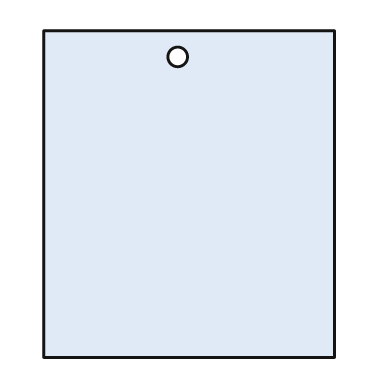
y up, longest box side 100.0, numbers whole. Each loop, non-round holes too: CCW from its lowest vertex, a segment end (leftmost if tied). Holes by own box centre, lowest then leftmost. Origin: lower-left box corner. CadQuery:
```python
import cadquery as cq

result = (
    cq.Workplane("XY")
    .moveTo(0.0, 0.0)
    .lineTo(89.0, 0.0)
    .lineTo(89.0, 100.0)
    .lineTo(0.0, 100.0)
    .close()
    .moveTo(41.0, 92.0)
    .circle(3.0)
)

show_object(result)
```